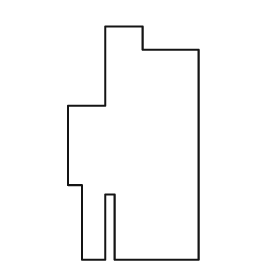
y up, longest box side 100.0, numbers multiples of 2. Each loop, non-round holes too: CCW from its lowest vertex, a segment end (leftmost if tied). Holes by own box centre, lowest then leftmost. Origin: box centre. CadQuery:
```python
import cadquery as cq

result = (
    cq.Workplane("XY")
    .moveTo(-22.0, -50.0)
    .lineTo(-12.0, -50.0)
    .lineTo(-12.0, -22.0)
    .lineTo(-8.0, -22.0)
    .lineTo(-8.0, -50.0)
    .lineTo(28.0, -50.0)
    .lineTo(28.0, 40.0)
    .lineTo(4.0, 40.0)
    .lineTo(4.0, 50.0)
    .lineTo(-12.0, 50.0)
    .lineTo(-12.0, 16.0)
    .lineTo(-28.0, 16.0)
    .lineTo(-28.0, -18.0)
    .lineTo(-22.0, -18.0)
    .close()
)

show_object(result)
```